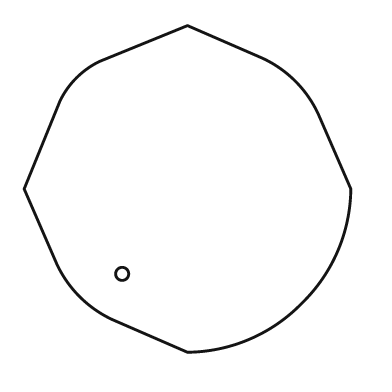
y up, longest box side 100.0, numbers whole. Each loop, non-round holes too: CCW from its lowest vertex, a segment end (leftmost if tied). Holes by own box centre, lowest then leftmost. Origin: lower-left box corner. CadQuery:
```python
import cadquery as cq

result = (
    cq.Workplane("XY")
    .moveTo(50.0, 0.0)
    .threePointArc((69.0, 4.0), (85.0, 15.0))
    .threePointArc((96.0, 31.0), (100.0, 50.0))
    .lineTo(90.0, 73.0)
    .threePointArc((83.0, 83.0), (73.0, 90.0))
    .lineTo(50.0, 100.0)
    .lineTo(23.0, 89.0)
    .threePointArc((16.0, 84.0), (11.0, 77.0))
    .lineTo(0.0, 50.0)
    .lineTo(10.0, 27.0)
    .threePointArc((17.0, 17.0), (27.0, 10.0))
    .close()
    .moveTo(30.0, 24.0)
    .circle(2.0)
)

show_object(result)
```